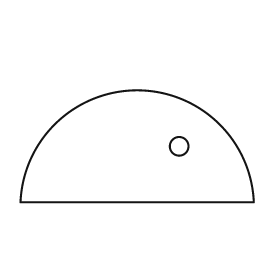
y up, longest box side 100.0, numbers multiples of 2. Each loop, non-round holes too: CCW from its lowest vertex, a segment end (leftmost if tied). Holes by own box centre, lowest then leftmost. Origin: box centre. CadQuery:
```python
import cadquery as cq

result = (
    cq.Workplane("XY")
    .moveTo(-50.0, -24.0)
    .lineTo(50.0, -24.0)
    .threePointArc((0.0, 24.0), (-50.0, -24.0))
    .close()
    .moveTo(18.0, 0.0)
    .circle(4.0)
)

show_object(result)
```